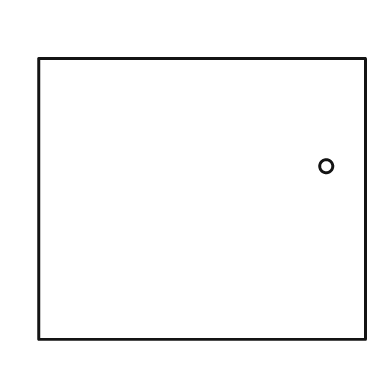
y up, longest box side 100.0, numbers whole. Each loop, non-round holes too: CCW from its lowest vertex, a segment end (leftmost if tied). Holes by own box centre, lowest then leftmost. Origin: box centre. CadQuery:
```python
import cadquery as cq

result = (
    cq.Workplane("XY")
    .moveTo(-50.0, -43.0)
    .lineTo(50.0, -43.0)
    .lineTo(50.0, 43.0)
    .lineTo(-50.0, 43.0)
    .close()
    .moveTo(38.0, 10.0)
    .circle(2.0)
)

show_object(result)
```